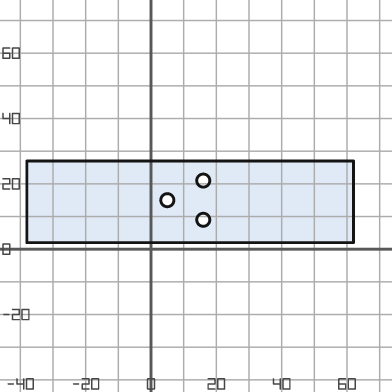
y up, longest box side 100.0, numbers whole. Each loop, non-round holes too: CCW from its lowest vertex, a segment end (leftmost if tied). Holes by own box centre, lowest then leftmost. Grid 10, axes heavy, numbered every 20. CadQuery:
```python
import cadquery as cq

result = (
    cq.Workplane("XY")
    .moveTo(-38.0, 2.0)
    .lineTo(62.0, 2.0)
    .lineTo(62.0, 27.0)
    .lineTo(-38.0, 27.0)
    .close()
    .moveTo(16.0, 9.0)
    .circle(2.0)
    .moveTo(5.0, 15.0)
    .circle(2.0)
    .moveTo(16.0, 21.0)
    .circle(2.0)
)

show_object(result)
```